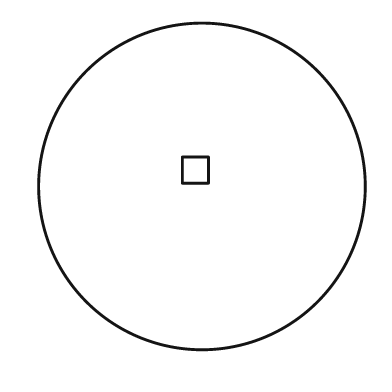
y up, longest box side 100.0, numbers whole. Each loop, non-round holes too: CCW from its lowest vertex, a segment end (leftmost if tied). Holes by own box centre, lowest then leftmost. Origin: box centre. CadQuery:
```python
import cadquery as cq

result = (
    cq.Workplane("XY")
    .moveTo(0.0, 0.0)
    .circle(50.0)
    .moveTo(-6.0, 1.0)
    .lineTo(2.0, 1.0)
    .lineTo(2.0, 9.0)
    .lineTo(-6.0, 9.0)
    .close()
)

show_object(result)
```